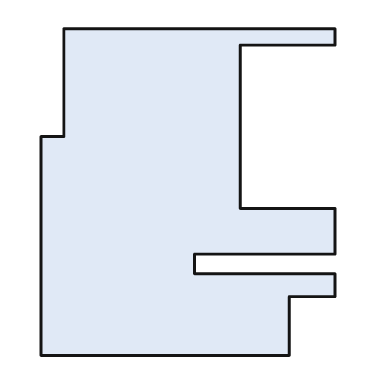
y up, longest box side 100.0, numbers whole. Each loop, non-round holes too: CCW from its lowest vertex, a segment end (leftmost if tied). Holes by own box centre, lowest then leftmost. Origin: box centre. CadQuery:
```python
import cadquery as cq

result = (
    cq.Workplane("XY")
    .moveTo(-45.0, -50.0)
    .lineTo(31.0, -50.0)
    .lineTo(31.0, -32.0)
    .lineTo(45.0, -32.0)
    .lineTo(45.0, -25.0)
    .lineTo(2.0, -25.0)
    .lineTo(2.0, -19.0)
    .lineTo(45.0, -19.0)
    .lineTo(45.0, -5.0)
    .lineTo(16.0, -5.0)
    .lineTo(16.0, 45.0)
    .lineTo(45.0, 45.0)
    .lineTo(45.0, 50.0)
    .lineTo(-38.0, 50.0)
    .lineTo(-38.0, 17.0)
    .lineTo(-45.0, 17.0)
    .close()
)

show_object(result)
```